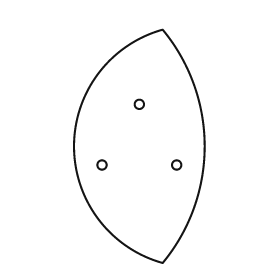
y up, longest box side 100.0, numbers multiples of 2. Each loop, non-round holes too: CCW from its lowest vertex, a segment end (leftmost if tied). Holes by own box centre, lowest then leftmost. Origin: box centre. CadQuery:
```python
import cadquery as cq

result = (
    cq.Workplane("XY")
    .moveTo(10.0, -50.0)
    .threePointArc((28.0, 0.0), (10.0, 50.0))
    .threePointArc((-28.0, 0.0), (10.0, -50.0))
    .close()
    .moveTo(-16.0, -8.0)
    .circle(2.0)
    .moveTo(16.0, -8.0)
    .circle(2.0)
    .moveTo(0.0, 18.0)
    .circle(2.0)
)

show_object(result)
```